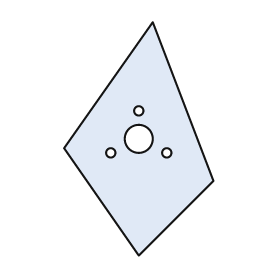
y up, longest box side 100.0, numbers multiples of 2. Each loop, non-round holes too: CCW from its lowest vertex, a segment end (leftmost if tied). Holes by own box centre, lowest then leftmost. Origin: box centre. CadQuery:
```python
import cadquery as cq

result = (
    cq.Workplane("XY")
    .moveTo(0.0, -50.0)
    .lineTo(32.0, -18.0)
    .lineTo(6.0, 50.0)
    .lineTo(-32.0, -4.0)
    .close()
    .moveTo(-12.0, -6.0)
    .circle(2.0)
    .moveTo(12.0, -6.0)
    .circle(2.0)
    .moveTo(0.0, 0.0)
    .circle(6.0)
    .moveTo(0.0, 12.0)
    .circle(2.0)
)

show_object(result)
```